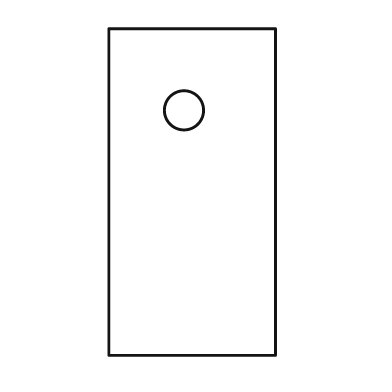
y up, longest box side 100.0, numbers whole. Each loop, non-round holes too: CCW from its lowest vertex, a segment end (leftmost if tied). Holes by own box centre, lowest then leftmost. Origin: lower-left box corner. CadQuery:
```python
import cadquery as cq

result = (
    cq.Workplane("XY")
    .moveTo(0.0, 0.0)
    .lineTo(51.0, 0.0)
    .lineTo(51.0, 100.0)
    .lineTo(0.0, 100.0)
    .close()
    .moveTo(23.0, 75.0)
    .circle(6.0)
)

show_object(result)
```